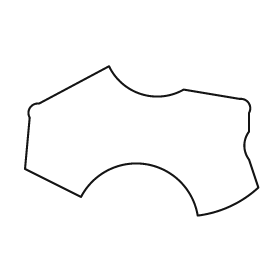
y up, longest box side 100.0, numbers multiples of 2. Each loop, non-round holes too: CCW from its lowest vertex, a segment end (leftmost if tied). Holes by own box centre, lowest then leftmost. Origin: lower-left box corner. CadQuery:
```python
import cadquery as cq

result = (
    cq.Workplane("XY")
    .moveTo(74.0, 0.0)
    .threePointArc((88.0, 4.0), (100.0, 12.0))
    .lineTo(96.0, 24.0)
    .threePointArc((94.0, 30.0), (96.0, 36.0))
    .lineTo(96.0, 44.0)
    .threePointArc((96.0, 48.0), (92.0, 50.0))
    .lineTo(68.0, 54.0)
    .threePointArc((50.0, 52.0), (36.0, 64.0))
    .lineTo(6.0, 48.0)
    .threePointArc((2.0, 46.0), (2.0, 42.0))
    .lineTo(0.0, 20.0)
    .lineTo(24.0, 8.0)
    .threePointArc((52.0, 22.0), (74.0, 0.0))
    .close()
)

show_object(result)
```